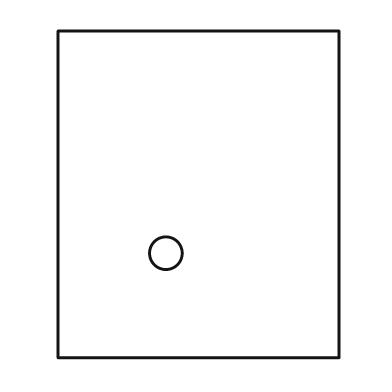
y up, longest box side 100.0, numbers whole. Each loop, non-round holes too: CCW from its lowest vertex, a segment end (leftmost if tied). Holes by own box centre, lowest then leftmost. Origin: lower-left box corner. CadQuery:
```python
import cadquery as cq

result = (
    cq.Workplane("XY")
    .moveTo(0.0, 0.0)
    .lineTo(86.0, 0.0)
    .lineTo(86.0, 100.0)
    .lineTo(0.0, 100.0)
    .close()
    .moveTo(33.0, 32.0)
    .circle(5.0)
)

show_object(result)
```